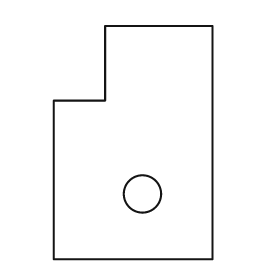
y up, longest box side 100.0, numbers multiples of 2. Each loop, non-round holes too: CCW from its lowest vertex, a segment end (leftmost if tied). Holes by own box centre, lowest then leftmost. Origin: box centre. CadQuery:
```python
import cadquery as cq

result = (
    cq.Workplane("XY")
    .moveTo(-34.0, -50.0)
    .lineTo(34.0, -50.0)
    .lineTo(34.0, 50.0)
    .lineTo(-12.0, 50.0)
    .lineTo(-12.0, 18.0)
    .lineTo(-34.0, 18.0)
    .close()
    .moveTo(4.0, -22.0)
    .circle(8.0)
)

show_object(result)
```